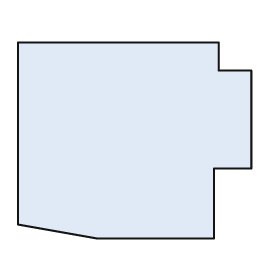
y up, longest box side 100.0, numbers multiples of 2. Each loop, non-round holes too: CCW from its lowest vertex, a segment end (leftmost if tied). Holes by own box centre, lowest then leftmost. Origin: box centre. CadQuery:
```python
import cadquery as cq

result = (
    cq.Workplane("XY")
    .moveTo(-16.0, -42.0)
    .lineTo(34.0, -42.0)
    .lineTo(34.0, -12.0)
    .lineTo(50.0, -12.0)
    .lineTo(50.0, 30.0)
    .lineTo(36.0, 30.0)
    .lineTo(36.0, 42.0)
    .lineTo(-50.0, 42.0)
    .lineTo(-50.0, -36.0)
    .close()
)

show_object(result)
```